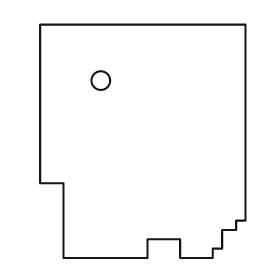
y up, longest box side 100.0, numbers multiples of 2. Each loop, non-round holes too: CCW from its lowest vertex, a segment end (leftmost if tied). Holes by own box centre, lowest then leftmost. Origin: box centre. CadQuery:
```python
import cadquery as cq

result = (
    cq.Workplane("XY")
    .moveTo(-34.0, -50.0)
    .lineTo(2.0, -50.0)
    .lineTo(2.0, -42.0)
    .lineTo(16.0, -42.0)
    .lineTo(16.0, -50.0)
    .lineTo(30.0, -50.0)
    .lineTo(30.0, -46.0)
    .lineTo(34.0, -46.0)
    .lineTo(34.0, -38.0)
    .lineTo(40.0, -38.0)
    .lineTo(40.0, -34.0)
    .lineTo(44.0, -34.0)
    .lineTo(44.0, 50.0)
    .lineTo(-44.0, 50.0)
    .lineTo(-44.0, -18.0)
    .lineTo(-34.0, -18.0)
    .close()
    .moveTo(-18.0, 26.0)
    .circle(4.0)
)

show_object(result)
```